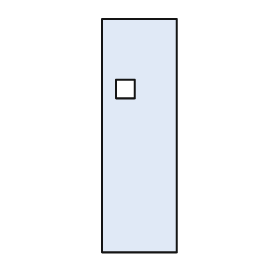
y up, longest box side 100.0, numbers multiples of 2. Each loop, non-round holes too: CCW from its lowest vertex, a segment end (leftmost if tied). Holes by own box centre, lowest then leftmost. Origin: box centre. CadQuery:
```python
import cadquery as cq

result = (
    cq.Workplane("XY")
    .moveTo(-16.0, -50.0)
    .lineTo(16.0, -50.0)
    .lineTo(16.0, 50.0)
    .lineTo(-16.0, 50.0)
    .close()
    .moveTo(-10.0, 16.0)
    .lineTo(-2.0, 16.0)
    .lineTo(-2.0, 24.0)
    .lineTo(-10.0, 24.0)
    .close()
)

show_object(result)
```